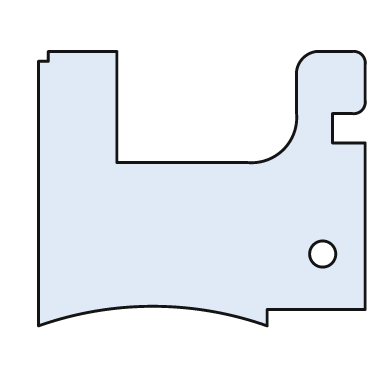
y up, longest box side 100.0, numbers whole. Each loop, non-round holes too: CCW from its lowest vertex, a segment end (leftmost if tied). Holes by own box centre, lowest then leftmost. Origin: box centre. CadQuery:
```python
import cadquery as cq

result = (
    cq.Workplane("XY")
    .moveTo(-50.0, -42.0)
    .threePointArc((-15.0, -36.0), (20.0, -42.0))
    .lineTo(20.0, -37.0)
    .lineTo(50.0, -37.0)
    .lineTo(50.0, 14.0)
    .lineTo(40.0, 14.0)
    .lineTo(40.0, 23.0)
    .lineTo(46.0, 23.0)
    .threePointArc((49.0, 24.0), (50.0, 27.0))
    .lineTo(50.0, 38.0)
    .threePointArc((49.0, 41.0), (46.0, 42.0))
    .lineTo(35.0, 42.0)
    .threePointArc((31.0, 40.0), (29.0, 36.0))
    .lineTo(29.0, 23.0)
    .threePointArc((25.0, 12.0), (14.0, 8.0))
    .lineTo(-26.0, 8.0)
    .lineTo(-26.0, 42.0)
    .lineTo(-47.0, 42.0)
    .lineTo(-47.0, 39.0)
    .lineTo(-50.0, 39.0)
    .close()
    .moveTo(37.0, -20.0)
    .circle(4.0)
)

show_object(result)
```